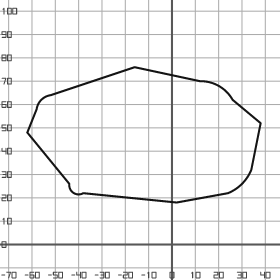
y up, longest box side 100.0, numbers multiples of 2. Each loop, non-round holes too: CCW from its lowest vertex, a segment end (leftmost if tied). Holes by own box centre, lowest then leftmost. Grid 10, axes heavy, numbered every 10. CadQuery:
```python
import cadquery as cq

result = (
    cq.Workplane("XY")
    .moveTo(2.0, 18.0)
    .lineTo(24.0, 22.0)
    .threePointArc((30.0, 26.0), (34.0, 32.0))
    .lineTo(38.0, 52.0)
    .lineTo(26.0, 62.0)
    .threePointArc((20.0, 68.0), (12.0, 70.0))
    .lineTo(-16.0, 76.0)
    .lineTo(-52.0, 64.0)
    .threePointArc((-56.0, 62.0), (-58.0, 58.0))
    .lineTo(-62.0, 48.0)
    .lineTo(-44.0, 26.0)
    .threePointArc((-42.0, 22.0), (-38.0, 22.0))
    .close()
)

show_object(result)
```